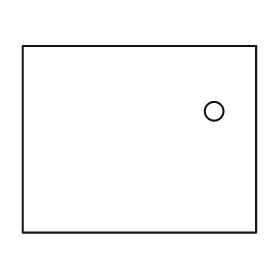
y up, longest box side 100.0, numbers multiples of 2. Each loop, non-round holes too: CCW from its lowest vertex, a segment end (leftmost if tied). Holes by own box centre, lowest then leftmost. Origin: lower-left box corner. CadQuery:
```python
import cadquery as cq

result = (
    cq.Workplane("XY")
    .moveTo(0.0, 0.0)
    .lineTo(100.0, 0.0)
    .lineTo(100.0, 80.0)
    .lineTo(0.0, 80.0)
    .close()
    .moveTo(82.0, 52.0)
    .circle(4.0)
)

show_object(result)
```